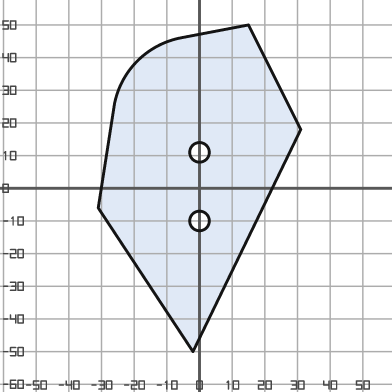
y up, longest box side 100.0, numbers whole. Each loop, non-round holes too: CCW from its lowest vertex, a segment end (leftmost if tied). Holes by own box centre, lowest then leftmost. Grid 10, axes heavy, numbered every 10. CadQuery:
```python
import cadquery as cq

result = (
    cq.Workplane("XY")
    .moveTo(-2.0, -50.0)
    .lineTo(31.0, 18.0)
    .lineTo(15.0, 50.0)
    .lineTo(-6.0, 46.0)
    .threePointArc((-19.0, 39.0), (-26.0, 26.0))
    .lineTo(-31.0, -6.0)
    .close()
    .moveTo(0.0, -10.0)
    .circle(3.0)
    .moveTo(0.0, 11.0)
    .circle(3.0)
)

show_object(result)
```